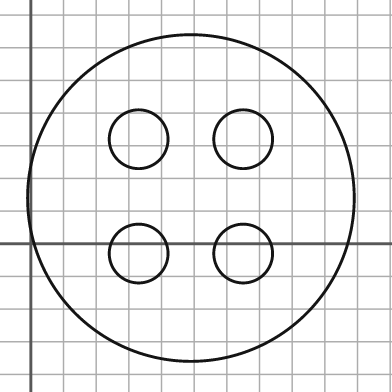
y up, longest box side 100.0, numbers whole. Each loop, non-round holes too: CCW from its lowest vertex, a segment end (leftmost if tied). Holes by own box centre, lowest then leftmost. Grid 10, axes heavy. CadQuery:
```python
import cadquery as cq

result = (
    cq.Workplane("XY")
    .moveTo(49.0, 14.0)
    .circle(50.0)
    .moveTo(33.0, -3.0)
    .circle(9.0)
    .moveTo(65.0, -3.0)
    .circle(9.0)
    .moveTo(33.0, 32.0)
    .circle(9.0)
    .moveTo(65.0, 32.0)
    .circle(9.0)
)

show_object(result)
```